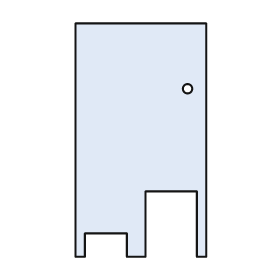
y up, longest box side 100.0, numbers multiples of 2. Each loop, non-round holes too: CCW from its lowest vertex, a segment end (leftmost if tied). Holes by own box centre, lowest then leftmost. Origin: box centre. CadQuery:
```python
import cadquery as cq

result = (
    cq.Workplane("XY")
    .moveTo(-28.0, -50.0)
    .lineTo(-24.0, -50.0)
    .lineTo(-24.0, -40.0)
    .lineTo(-6.0, -40.0)
    .lineTo(-6.0, -50.0)
    .lineTo(2.0, -50.0)
    .lineTo(2.0, -22.0)
    .lineTo(24.0, -22.0)
    .lineTo(24.0, -50.0)
    .lineTo(28.0, -50.0)
    .lineTo(28.0, 50.0)
    .lineTo(-28.0, 50.0)
    .close()
    .moveTo(20.0, 22.0)
    .circle(2.0)
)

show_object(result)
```